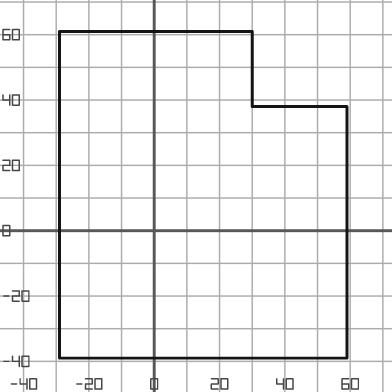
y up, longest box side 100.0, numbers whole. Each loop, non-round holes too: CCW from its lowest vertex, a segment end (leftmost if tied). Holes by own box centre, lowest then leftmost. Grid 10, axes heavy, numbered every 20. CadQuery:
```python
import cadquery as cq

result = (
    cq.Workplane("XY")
    .moveTo(-29.0, -39.0)
    .lineTo(59.0, -39.0)
    .lineTo(59.0, 38.0)
    .lineTo(30.0, 38.0)
    .lineTo(30.0, 61.0)
    .lineTo(-29.0, 61.0)
    .close()
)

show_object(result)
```